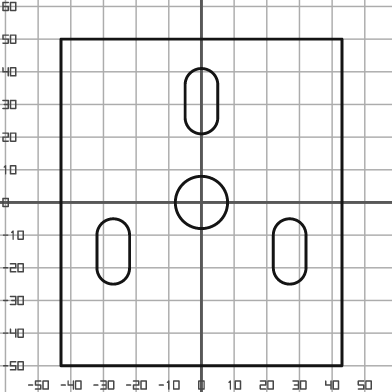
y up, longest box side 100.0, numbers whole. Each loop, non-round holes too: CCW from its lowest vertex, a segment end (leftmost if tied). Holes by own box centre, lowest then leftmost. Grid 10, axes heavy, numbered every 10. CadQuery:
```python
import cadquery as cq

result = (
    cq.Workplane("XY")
    .moveTo(-43.0, -50.0)
    .lineTo(43.0, -50.0)
    .lineTo(43.0, 50.0)
    .lineTo(-43.0, 50.0)
    .close()
    .moveTo(-32.0, -20.0)
    .threePointArc((-27.0, -25.0), (-22.0, -20.0))
    .lineTo(-22.0, -10.0)
    .threePointArc((-27.0, -5.0), (-32.0, -10.0))
    .close()
    .moveTo(22.0, -20.0)
    .threePointArc((27.0, -25.0), (32.0, -20.0))
    .lineTo(32.0, -10.0)
    .threePointArc((27.0, -5.0), (22.0, -10.0))
    .close()
    .moveTo(0.0, 0.0)
    .circle(8.0)
    .moveTo(-5.0, 26.0)
    .threePointArc((0.0, 21.0), (5.0, 26.0))
    .lineTo(5.0, 36.0)
    .threePointArc((0.0, 41.0), (-5.0, 36.0))
    .close()
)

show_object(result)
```